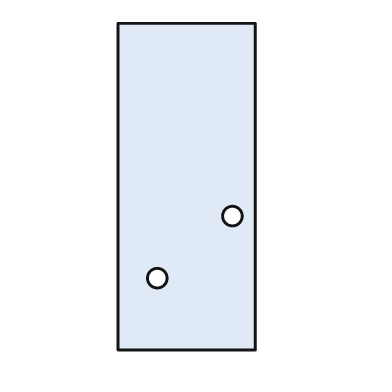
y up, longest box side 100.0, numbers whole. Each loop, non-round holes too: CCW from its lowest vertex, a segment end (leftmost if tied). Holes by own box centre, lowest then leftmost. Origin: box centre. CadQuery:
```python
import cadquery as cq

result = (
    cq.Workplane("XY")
    .moveTo(-21.0, -50.0)
    .lineTo(21.0, -50.0)
    .lineTo(21.0, 50.0)
    .lineTo(-21.0, 50.0)
    .close()
    .moveTo(-9.0, -28.0)
    .circle(3.0)
    .moveTo(14.0, -9.0)
    .circle(3.0)
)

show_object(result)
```